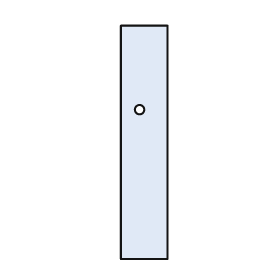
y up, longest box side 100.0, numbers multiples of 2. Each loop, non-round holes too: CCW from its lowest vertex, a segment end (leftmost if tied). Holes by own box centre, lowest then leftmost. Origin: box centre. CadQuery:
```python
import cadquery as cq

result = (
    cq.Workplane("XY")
    .moveTo(-10.0, -50.0)
    .lineTo(10.0, -50.0)
    .lineTo(10.0, 50.0)
    .lineTo(-10.0, 50.0)
    .close()
    .moveTo(-2.0, 14.0)
    .circle(2.0)
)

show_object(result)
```